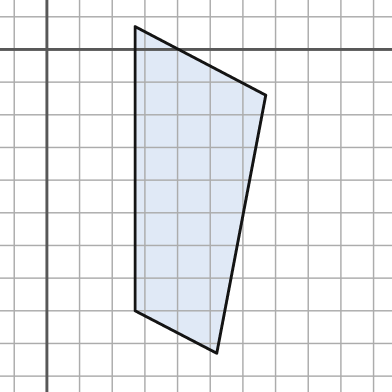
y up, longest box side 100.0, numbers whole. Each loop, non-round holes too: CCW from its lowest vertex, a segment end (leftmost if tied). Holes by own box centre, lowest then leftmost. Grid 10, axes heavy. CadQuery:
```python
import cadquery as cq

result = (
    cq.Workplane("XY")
    .moveTo(52.0, -93.0)
    .lineTo(67.0, -14.0)
    .lineTo(27.0, 7.0)
    .lineTo(27.0, -80.0)
    .close()
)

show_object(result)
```